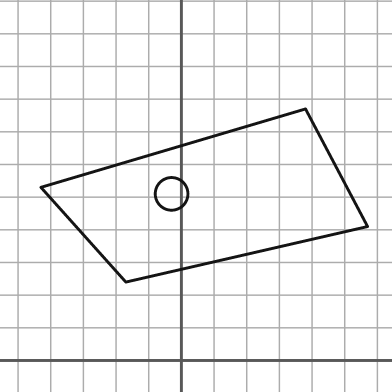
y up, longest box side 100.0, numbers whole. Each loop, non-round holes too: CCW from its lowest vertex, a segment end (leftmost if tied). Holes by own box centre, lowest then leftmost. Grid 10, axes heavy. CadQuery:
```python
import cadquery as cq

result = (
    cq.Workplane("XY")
    .moveTo(-17.0, 24.0)
    .lineTo(57.0, 41.0)
    .lineTo(38.0, 77.0)
    .lineTo(-43.0, 53.0)
    .close()
    .moveTo(-3.0, 51.0)
    .circle(5.0)
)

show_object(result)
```